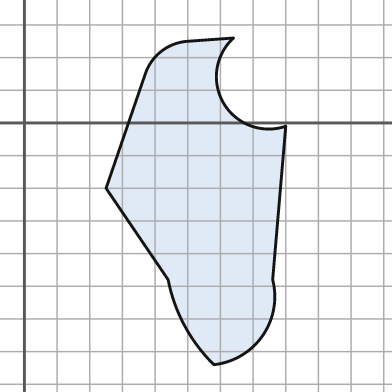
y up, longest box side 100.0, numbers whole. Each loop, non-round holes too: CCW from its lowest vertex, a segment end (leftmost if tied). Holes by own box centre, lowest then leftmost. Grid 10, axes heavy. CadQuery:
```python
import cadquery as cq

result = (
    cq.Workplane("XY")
    .moveTo(58.0, -74.0)
    .threePointArc((73.0, -65.0), (76.0, -48.0))
    .lineTo(80.0, -1.0)
    .threePointArc((61.0, 6.0), (64.0, 26.0))
    .lineTo(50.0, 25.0)
    .threePointArc((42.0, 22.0), (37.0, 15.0))
    .lineTo(25.0, -20.0)
    .lineTo(44.0, -48.0)
    .threePointArc((49.0, -62.0), (58.0, -74.0))
    .close()
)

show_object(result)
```